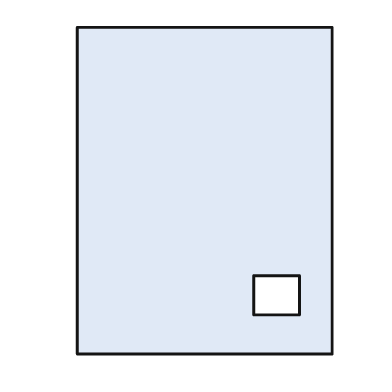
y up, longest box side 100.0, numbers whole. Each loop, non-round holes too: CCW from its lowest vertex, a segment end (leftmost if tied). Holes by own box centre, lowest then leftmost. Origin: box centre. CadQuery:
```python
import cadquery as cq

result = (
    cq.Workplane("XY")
    .moveTo(-39.0, -50.0)
    .lineTo(39.0, -50.0)
    .lineTo(39.0, 50.0)
    .lineTo(-39.0, 50.0)
    .close()
    .moveTo(15.0, -38.0)
    .lineTo(29.0, -38.0)
    .lineTo(29.0, -26.0)
    .lineTo(15.0, -26.0)
    .close()
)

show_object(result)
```